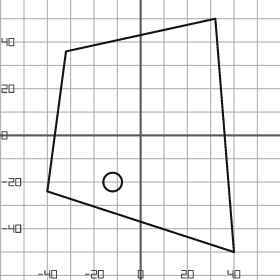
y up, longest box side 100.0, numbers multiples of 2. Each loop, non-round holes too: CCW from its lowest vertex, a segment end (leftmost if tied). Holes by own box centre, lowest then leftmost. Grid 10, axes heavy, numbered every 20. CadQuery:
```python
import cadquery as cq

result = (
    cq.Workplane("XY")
    .moveTo(40.0, -50.0)
    .lineTo(32.0, 50.0)
    .lineTo(-32.0, 36.0)
    .lineTo(-40.0, -24.0)
    .close()
    .moveTo(-12.0, -20.0)
    .circle(4.0)
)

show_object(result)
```